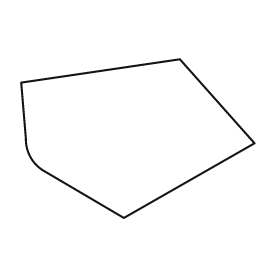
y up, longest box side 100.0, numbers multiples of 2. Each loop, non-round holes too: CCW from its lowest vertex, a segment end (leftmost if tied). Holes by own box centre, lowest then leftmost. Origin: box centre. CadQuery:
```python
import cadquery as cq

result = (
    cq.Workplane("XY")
    .moveTo(-6.0, -34.0)
    .lineTo(50.0, -2.0)
    .lineTo(18.0, 34.0)
    .lineTo(-50.0, 24.0)
    .lineTo(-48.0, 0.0)
    .threePointArc((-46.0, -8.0), (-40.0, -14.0))
    .close()
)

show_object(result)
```